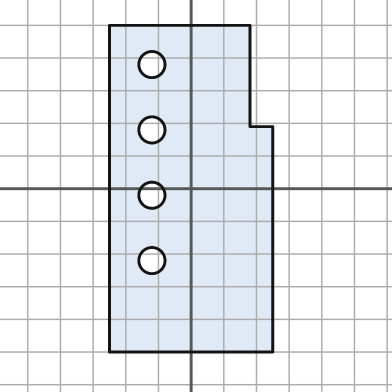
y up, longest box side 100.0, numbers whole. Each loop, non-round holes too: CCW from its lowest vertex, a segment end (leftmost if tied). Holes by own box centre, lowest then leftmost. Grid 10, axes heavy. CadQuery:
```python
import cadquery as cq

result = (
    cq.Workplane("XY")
    .moveTo(-25.0, -50.0)
    .lineTo(25.0, -50.0)
    .lineTo(25.0, 19.0)
    .lineTo(18.0, 19.0)
    .lineTo(18.0, 50.0)
    .lineTo(-25.0, 50.0)
    .close()
    .moveTo(-12.0, -22.0)
    .circle(4.0)
    .moveTo(-12.0, -2.0)
    .circle(4.0)
    .moveTo(-12.0, 18.0)
    .circle(4.0)
    .moveTo(-12.0, 38.0)
    .circle(4.0)
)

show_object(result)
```